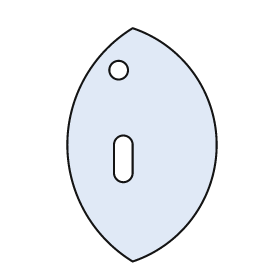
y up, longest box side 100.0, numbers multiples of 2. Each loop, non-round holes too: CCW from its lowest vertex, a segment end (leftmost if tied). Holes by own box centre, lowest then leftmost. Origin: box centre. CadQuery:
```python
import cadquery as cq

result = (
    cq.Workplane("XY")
    .moveTo(-4.0, -50.0)
    .threePointArc((32.0, 0.0), (-4.0, 50.0))
    .threePointArc((-32.0, 0.0), (-4.0, -50.0))
    .close()
    .moveTo(-12.0, -12.0)
    .threePointArc((-8.0, -16.0), (-4.0, -12.0))
    .lineTo(-4.0, 0.0)
    .threePointArc((-8.0, 4.0), (-12.0, 0.0))
    .close()
    .moveTo(-10.0, 32.0)
    .circle(4.0)
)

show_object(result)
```